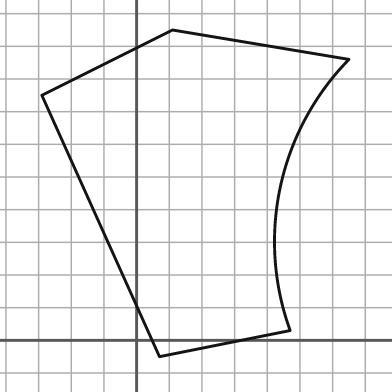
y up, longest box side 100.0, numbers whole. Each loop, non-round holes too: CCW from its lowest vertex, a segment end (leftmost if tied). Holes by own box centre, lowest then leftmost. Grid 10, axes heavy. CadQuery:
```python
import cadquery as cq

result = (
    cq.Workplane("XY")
    .moveTo(7.0, -5.0)
    .lineTo(47.0, 3.0)
    .threePointArc((44.0, 47.0), (65.0, 86.0))
    .lineTo(11.0, 95.0)
    .lineTo(-29.0, 75.0)
    .close()
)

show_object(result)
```